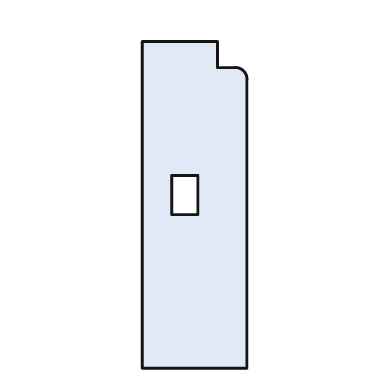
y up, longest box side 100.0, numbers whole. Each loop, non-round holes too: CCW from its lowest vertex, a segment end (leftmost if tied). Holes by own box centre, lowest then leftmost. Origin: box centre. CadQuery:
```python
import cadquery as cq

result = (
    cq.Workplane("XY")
    .moveTo(-16.0, -50.0)
    .lineTo(16.0, -50.0)
    .lineTo(16.0, 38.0)
    .threePointArc((15.0, 41.0), (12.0, 42.0))
    .lineTo(7.0, 42.0)
    .lineTo(7.0, 50.0)
    .lineTo(-16.0, 50.0)
    .close()
    .moveTo(-7.0, -3.0)
    .lineTo(1.0, -3.0)
    .lineTo(1.0, 9.0)
    .lineTo(-7.0, 9.0)
    .close()
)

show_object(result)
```